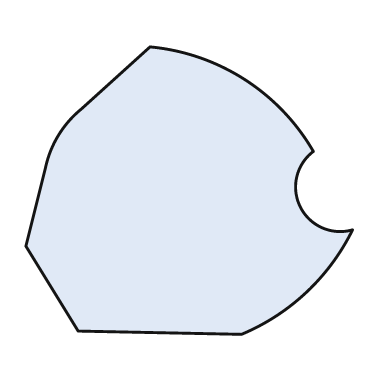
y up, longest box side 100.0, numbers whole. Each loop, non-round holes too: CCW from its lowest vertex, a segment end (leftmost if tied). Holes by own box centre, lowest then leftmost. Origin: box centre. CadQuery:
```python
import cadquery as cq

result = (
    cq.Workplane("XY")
    .moveTo(16.0, -44.0)
    .threePointArc((36.0, -31.0), (50.0, -12.0))
    .threePointArc((34.0, -5.0), (38.0, 12.0))
    .threePointArc((17.0, 34.0), (-12.0, 44.0))
    .lineTo(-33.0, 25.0)
    .threePointArc((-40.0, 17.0), (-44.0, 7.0))
    .lineTo(-50.0, -17.0)
    .lineTo(-34.0, -43.0)
    .close()
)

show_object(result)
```